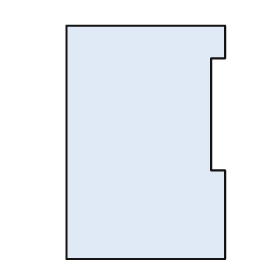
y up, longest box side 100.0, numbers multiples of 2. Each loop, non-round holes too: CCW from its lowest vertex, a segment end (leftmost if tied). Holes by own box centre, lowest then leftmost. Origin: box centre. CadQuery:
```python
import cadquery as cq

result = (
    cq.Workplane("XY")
    .moveTo(-34.0, -50.0)
    .lineTo(34.0, -50.0)
    .lineTo(34.0, -12.0)
    .lineTo(28.0, -12.0)
    .lineTo(28.0, 36.0)
    .lineTo(34.0, 36.0)
    .lineTo(34.0, 50.0)
    .lineTo(-34.0, 50.0)
    .close()
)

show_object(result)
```